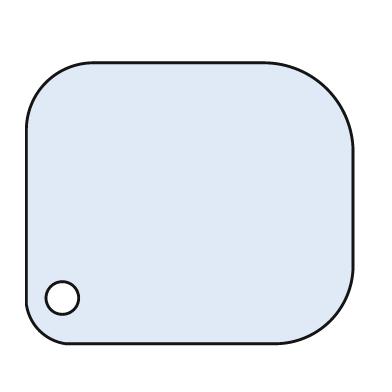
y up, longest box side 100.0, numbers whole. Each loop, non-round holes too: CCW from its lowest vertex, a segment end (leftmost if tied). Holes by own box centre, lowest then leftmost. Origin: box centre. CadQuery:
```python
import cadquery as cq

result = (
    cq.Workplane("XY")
    .moveTo(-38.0, -43.0)
    .lineTo(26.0, -43.0)
    .threePointArc((43.0, -36.0), (50.0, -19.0))
    .lineTo(50.0, 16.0)
    .threePointArc((42.0, 35.0), (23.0, 43.0))
    .lineTo(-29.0, 43.0)
    .threePointArc((-44.0, 37.0), (-50.0, 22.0))
    .lineTo(-50.0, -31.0)
    .threePointArc((-46.0, -39.0), (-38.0, -43.0))
    .close()
    .moveTo(-39.0, -29.0)
    .circle(5.0)
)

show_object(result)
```